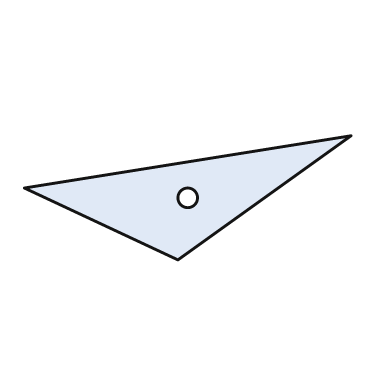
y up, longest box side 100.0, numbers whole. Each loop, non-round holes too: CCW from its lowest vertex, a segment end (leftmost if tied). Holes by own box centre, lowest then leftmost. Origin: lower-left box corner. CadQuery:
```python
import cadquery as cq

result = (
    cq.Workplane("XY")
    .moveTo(47.0, 0.0)
    .lineTo(100.0, 38.0)
    .lineTo(0.0, 22.0)
    .close()
    .moveTo(50.0, 19.0)
    .circle(3.0)
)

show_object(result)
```